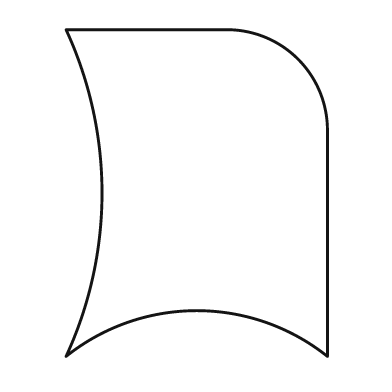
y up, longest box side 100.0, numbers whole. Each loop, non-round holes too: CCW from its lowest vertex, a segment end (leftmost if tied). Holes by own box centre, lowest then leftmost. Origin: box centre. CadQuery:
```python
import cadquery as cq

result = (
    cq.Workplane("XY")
    .moveTo(-40.0, -50.0)
    .threePointArc((0.0, -36.0), (40.0, -50.0))
    .lineTo(40.0, 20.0)
    .threePointArc((31.0, 41.0), (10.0, 50.0))
    .lineTo(-40.0, 50.0)
    .threePointArc((-29.0, 0.0), (-40.0, -50.0))
    .close()
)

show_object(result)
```